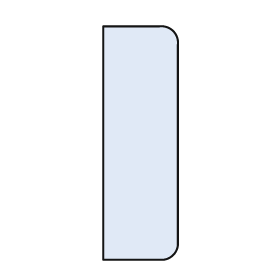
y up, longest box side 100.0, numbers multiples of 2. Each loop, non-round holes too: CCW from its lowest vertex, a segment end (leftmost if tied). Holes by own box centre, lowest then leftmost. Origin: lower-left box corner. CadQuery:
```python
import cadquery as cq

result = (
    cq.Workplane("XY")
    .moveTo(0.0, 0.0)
    .lineTo(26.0, 0.0)
    .threePointArc((30.0, 2.0), (32.0, 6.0))
    .lineTo(32.0, 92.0)
    .threePointArc((30.0, 98.0), (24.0, 100.0))
    .lineTo(0.0, 100.0)
    .close()
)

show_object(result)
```